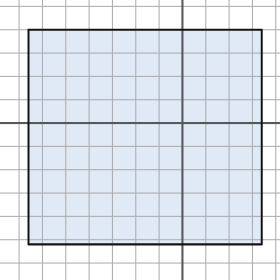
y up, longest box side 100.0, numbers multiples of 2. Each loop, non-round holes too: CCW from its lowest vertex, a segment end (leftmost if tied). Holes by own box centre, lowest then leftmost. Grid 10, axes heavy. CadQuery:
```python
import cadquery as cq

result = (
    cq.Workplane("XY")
    .moveTo(-66.0, -52.0)
    .lineTo(34.0, -52.0)
    .lineTo(34.0, 40.0)
    .lineTo(-66.0, 40.0)
    .close()
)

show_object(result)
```